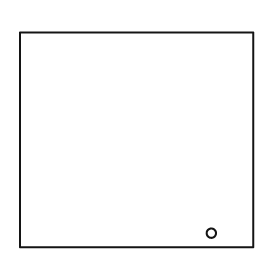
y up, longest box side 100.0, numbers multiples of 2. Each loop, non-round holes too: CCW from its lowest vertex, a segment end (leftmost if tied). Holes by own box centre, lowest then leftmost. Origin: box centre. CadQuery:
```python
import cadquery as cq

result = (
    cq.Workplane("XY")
    .moveTo(-50.0, -46.0)
    .lineTo(50.0, -46.0)
    .lineTo(50.0, 46.0)
    .lineTo(-50.0, 46.0)
    .close()
    .moveTo(32.0, -40.0)
    .circle(2.0)
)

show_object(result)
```